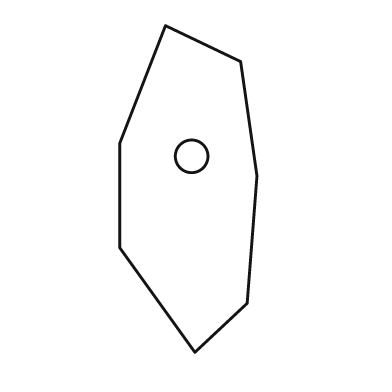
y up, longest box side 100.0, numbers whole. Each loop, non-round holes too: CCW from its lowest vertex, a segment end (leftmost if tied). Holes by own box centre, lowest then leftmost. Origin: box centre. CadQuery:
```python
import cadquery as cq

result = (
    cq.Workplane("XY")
    .moveTo(2.0, -50.0)
    .lineTo(18.0, -35.0)
    .lineTo(21.0, 4.0)
    .lineTo(16.0, 39.0)
    .lineTo(-7.0, 50.0)
    .lineTo(-21.0, 14.0)
    .lineTo(-21.0, -18.0)
    .close()
    .moveTo(1.0, 10.0)
    .circle(5.0)
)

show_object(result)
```